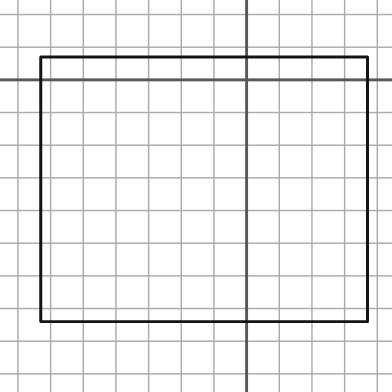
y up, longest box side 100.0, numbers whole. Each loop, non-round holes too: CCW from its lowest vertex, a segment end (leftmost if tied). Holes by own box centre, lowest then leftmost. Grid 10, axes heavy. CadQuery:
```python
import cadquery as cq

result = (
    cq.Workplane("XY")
    .moveTo(-63.0, -74.0)
    .lineTo(37.0, -74.0)
    .lineTo(37.0, 7.0)
    .lineTo(-63.0, 7.0)
    .close()
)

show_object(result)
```